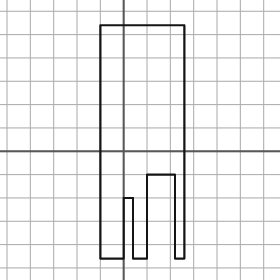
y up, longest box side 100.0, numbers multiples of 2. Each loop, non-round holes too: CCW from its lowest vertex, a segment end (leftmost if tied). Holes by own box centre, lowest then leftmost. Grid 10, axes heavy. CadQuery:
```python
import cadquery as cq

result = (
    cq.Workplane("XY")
    .moveTo(-10.0, -46.0)
    .lineTo(0.0, -46.0)
    .lineTo(0.0, -20.0)
    .lineTo(4.0, -20.0)
    .lineTo(4.0, -46.0)
    .lineTo(10.0, -46.0)
    .lineTo(10.0, -10.0)
    .lineTo(22.0, -10.0)
    .lineTo(22.0, -46.0)
    .lineTo(26.0, -46.0)
    .lineTo(26.0, 54.0)
    .lineTo(-10.0, 54.0)
    .close()
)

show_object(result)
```